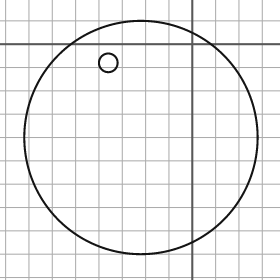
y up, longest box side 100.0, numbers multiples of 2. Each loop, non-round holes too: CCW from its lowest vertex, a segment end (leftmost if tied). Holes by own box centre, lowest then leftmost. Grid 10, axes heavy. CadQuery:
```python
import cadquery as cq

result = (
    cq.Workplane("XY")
    .moveTo(-22.0, -40.0)
    .circle(50.0)
    .moveTo(-36.0, -8.0)
    .circle(4.0)
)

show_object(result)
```